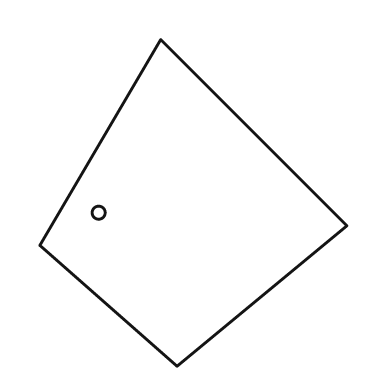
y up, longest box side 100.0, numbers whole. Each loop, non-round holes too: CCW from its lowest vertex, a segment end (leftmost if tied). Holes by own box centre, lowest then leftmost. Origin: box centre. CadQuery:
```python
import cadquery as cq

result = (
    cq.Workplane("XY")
    .moveTo(-5.0, -50.0)
    .lineTo(47.0, -7.0)
    .lineTo(-10.0, 50.0)
    .lineTo(-47.0, -13.0)
    .close()
    .moveTo(-29.0, -3.0)
    .circle(2.0)
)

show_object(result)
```